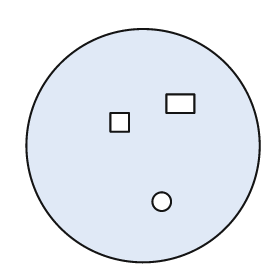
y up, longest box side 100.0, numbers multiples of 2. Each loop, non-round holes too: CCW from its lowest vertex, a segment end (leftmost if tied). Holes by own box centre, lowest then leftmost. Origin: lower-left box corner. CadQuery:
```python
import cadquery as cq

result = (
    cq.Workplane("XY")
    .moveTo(50.0, 50.0)
    .circle(50.0)
    .moveTo(58.0, 26.0)
    .circle(4.0)
    .moveTo(36.0, 56.0)
    .lineTo(44.0, 56.0)
    .lineTo(44.0, 64.0)
    .lineTo(36.0, 64.0)
    .close()
    .moveTo(60.0, 64.0)
    .lineTo(72.0, 64.0)
    .lineTo(72.0, 72.0)
    .lineTo(60.0, 72.0)
    .close()
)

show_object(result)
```